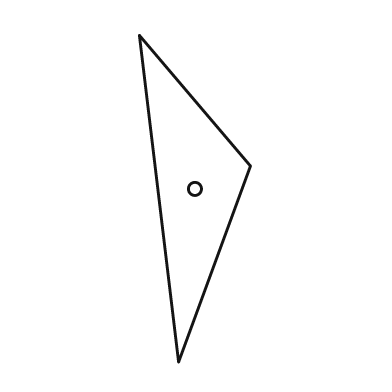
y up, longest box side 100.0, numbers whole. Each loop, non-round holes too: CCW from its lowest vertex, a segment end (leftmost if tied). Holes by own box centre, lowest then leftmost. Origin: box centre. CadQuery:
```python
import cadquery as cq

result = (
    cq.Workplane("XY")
    .moveTo(-5.0, -50.0)
    .lineTo(17.0, 10.0)
    .lineTo(-17.0, 50.0)
    .close()
    .moveTo(0.0, 3.0)
    .circle(2.0)
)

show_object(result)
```